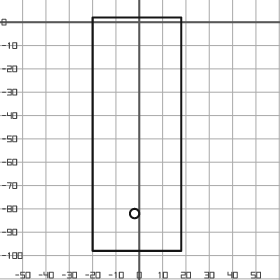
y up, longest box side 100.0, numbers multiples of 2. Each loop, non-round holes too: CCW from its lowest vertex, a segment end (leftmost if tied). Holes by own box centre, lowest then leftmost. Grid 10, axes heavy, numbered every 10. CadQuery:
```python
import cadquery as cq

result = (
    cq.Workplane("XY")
    .moveTo(-20.0, -98.0)
    .lineTo(18.0, -98.0)
    .lineTo(18.0, 2.0)
    .lineTo(-20.0, 2.0)
    .close()
    .moveTo(-2.0, -82.0)
    .circle(2.0)
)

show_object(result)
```